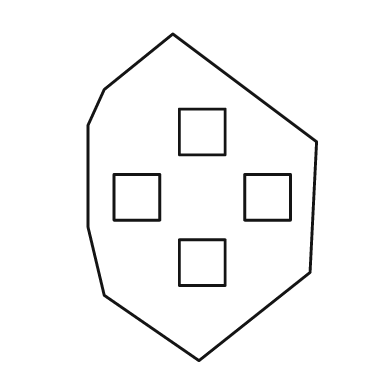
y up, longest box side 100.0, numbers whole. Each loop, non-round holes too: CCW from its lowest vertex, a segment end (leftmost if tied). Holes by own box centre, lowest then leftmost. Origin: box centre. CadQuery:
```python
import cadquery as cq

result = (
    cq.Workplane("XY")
    .moveTo(-1.0, -50.0)
    .lineTo(33.0, -23.0)
    .lineTo(35.0, 17.0)
    .lineTo(-9.0, 50.0)
    .lineTo(-30.0, 33.0)
    .lineTo(-35.0, 22.0)
    .lineTo(-35.0, -9.0)
    .lineTo(-30.0, -30.0)
    .close()
    .moveTo(-7.0, -27.0)
    .lineTo(7.0, -27.0)
    .lineTo(7.0, -13.0)
    .lineTo(-7.0, -13.0)
    .close()
    .moveTo(-27.0, -7.0)
    .lineTo(-13.0, -7.0)
    .lineTo(-13.0, 7.0)
    .lineTo(-27.0, 7.0)
    .close()
    .moveTo(13.0, -7.0)
    .lineTo(27.0, -7.0)
    .lineTo(27.0, 7.0)
    .lineTo(13.0, 7.0)
    .close()
    .moveTo(-7.0, 13.0)
    .lineTo(7.0, 13.0)
    .lineTo(7.0, 27.0)
    .lineTo(-7.0, 27.0)
    .close()
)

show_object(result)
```